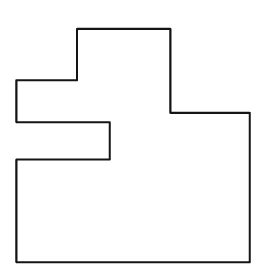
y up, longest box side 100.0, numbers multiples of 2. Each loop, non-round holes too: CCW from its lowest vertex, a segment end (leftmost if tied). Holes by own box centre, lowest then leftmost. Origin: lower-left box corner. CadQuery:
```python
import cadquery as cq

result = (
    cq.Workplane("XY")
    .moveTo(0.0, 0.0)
    .lineTo(100.0, 0.0)
    .lineTo(100.0, 64.0)
    .lineTo(66.0, 64.0)
    .lineTo(66.0, 100.0)
    .lineTo(26.0, 100.0)
    .lineTo(26.0, 78.0)
    .lineTo(0.0, 78.0)
    .lineTo(0.0, 60.0)
    .lineTo(40.0, 60.0)
    .lineTo(40.0, 44.0)
    .lineTo(0.0, 44.0)
    .close()
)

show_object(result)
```